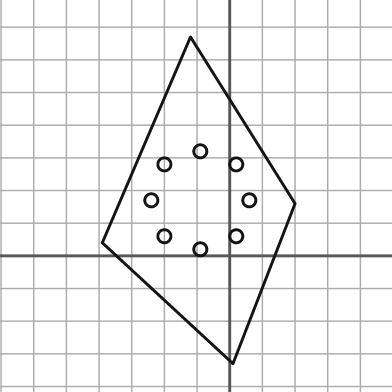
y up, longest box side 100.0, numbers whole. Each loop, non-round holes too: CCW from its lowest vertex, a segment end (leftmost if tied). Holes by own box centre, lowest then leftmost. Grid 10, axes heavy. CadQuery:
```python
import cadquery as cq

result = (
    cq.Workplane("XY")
    .moveTo(1.0, -33.0)
    .lineTo(20.0, 16.0)
    .lineTo(-12.0, 67.0)
    .lineTo(-39.0, 4.0)
    .close()
    .moveTo(-9.0, 2.0)
    .circle(2.0)
    .moveTo(-20.0, 6.0)
    .circle(2.0)
    .moveTo(2.0, 6.0)
    .circle(2.0)
    .moveTo(-24.0, 17.0)
    .circle(2.0)
    .moveTo(6.0, 17.0)
    .circle(2.0)
    .moveTo(-20.0, 28.0)
    .circle(2.0)
    .moveTo(2.0, 28.0)
    .circle(2.0)
    .moveTo(-9.0, 32.0)
    .circle(2.0)
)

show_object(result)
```